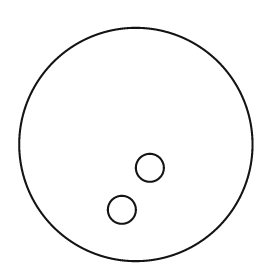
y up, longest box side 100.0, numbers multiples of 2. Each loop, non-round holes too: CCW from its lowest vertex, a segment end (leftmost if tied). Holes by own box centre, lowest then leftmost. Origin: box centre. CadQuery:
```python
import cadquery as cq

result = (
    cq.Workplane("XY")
    .moveTo(0.0, 0.0)
    .circle(50.0)
    .moveTo(-6.0, -28.0)
    .circle(6.0)
    .moveTo(6.0, -10.0)
    .circle(6.0)
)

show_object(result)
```